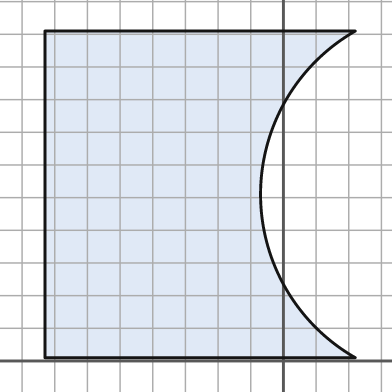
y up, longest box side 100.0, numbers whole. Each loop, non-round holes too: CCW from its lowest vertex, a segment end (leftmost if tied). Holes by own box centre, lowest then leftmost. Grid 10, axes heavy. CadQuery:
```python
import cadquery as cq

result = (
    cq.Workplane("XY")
    .moveTo(-73.0, 1.0)
    .lineTo(22.0, 1.0)
    .threePointArc((-7.0, 51.0), (22.0, 101.0))
    .lineTo(-73.0, 101.0)
    .close()
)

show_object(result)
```